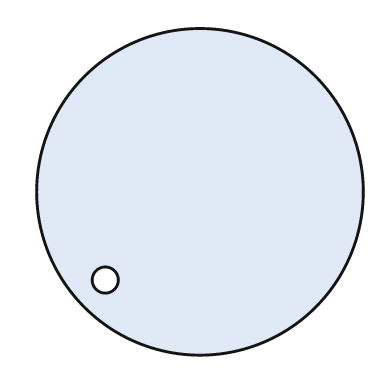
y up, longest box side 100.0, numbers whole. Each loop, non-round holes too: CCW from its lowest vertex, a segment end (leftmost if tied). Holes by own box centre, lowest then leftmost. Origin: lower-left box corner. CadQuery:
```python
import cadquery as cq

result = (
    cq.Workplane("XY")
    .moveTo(50.0, 50.0)
    .circle(50.0)
    .moveTo(21.0, 23.0)
    .circle(4.0)
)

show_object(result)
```